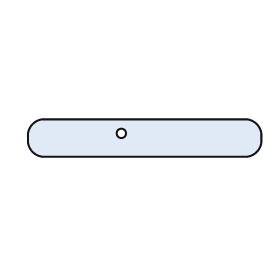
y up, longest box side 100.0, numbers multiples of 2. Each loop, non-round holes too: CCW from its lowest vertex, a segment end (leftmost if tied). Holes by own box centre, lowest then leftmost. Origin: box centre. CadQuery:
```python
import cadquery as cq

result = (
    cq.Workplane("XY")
    .moveTo(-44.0, -8.0)
    .lineTo(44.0, -8.0)
    .threePointArc((48.0, -6.0), (50.0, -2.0))
    .lineTo(50.0, 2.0)
    .threePointArc((48.0, 6.0), (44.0, 8.0))
    .lineTo(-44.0, 8.0)
    .threePointArc((-48.0, 6.0), (-50.0, 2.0))
    .lineTo(-50.0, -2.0)
    .threePointArc((-48.0, -6.0), (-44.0, -8.0))
    .close()
    .moveTo(-10.0, 2.0)
    .circle(2.0)
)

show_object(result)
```